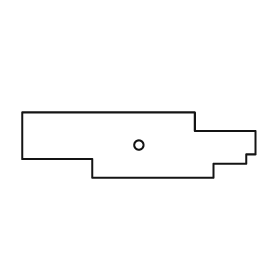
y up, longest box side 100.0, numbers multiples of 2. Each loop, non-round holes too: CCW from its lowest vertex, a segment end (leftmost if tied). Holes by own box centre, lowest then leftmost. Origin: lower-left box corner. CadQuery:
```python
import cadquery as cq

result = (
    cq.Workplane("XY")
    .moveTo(30.0, 0.0)
    .lineTo(82.0, 0.0)
    .lineTo(82.0, 6.0)
    .lineTo(96.0, 6.0)
    .lineTo(96.0, 10.0)
    .lineTo(100.0, 10.0)
    .lineTo(100.0, 20.0)
    .lineTo(74.0, 20.0)
    .lineTo(74.0, 28.0)
    .lineTo(0.0, 28.0)
    .lineTo(0.0, 8.0)
    .lineTo(30.0, 8.0)
    .close()
    .moveTo(50.0, 14.0)
    .circle(2.0)
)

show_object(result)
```